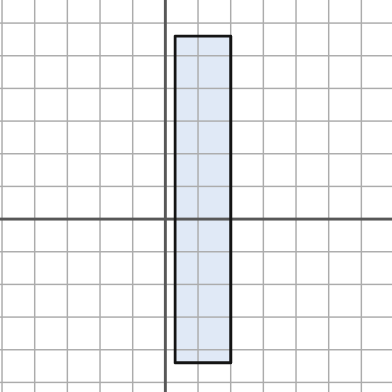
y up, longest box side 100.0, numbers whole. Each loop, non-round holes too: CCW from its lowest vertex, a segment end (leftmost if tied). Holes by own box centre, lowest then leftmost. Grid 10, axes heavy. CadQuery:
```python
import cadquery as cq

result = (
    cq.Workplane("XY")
    .moveTo(3.0, -44.0)
    .lineTo(20.0, -44.0)
    .lineTo(20.0, 56.0)
    .lineTo(3.0, 56.0)
    .close()
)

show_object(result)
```